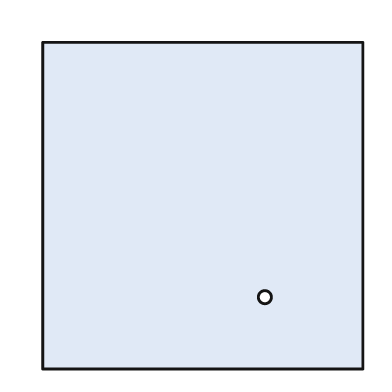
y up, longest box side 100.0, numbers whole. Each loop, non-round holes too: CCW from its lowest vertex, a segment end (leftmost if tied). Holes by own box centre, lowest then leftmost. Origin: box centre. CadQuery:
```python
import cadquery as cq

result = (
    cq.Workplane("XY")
    .moveTo(-49.0, -50.0)
    .lineTo(49.0, -50.0)
    .lineTo(49.0, 50.0)
    .lineTo(-49.0, 50.0)
    .close()
    .moveTo(19.0, -28.0)
    .circle(2.0)
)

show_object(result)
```